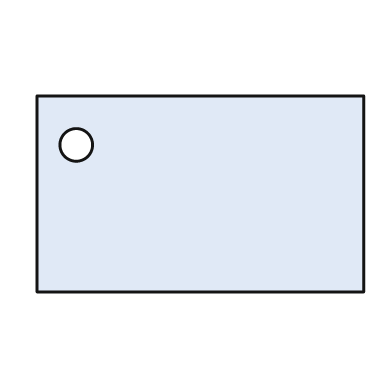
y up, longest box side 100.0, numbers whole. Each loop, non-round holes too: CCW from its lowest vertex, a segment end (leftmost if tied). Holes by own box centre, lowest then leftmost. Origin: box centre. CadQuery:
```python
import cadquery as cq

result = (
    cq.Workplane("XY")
    .moveTo(-50.0, -30.0)
    .lineTo(50.0, -30.0)
    .lineTo(50.0, 30.0)
    .lineTo(-50.0, 30.0)
    .close()
    .moveTo(-38.0, 15.0)
    .circle(5.0)
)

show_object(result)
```